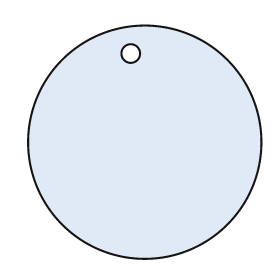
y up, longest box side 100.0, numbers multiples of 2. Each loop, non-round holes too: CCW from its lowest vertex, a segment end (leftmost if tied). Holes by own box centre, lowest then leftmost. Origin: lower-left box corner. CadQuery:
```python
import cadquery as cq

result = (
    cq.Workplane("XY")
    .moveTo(50.0, 50.0)
    .circle(50.0)
    .moveTo(44.0, 88.0)
    .circle(4.0)
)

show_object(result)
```